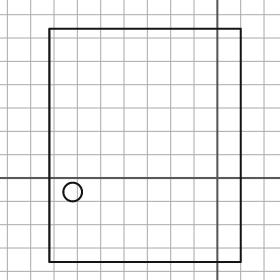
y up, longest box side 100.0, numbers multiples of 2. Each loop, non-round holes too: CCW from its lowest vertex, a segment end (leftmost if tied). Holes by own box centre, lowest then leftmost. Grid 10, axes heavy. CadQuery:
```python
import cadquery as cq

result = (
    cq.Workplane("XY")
    .moveTo(-72.0, -36.0)
    .lineTo(10.0, -36.0)
    .lineTo(10.0, 64.0)
    .lineTo(-72.0, 64.0)
    .close()
    .moveTo(-62.0, -6.0)
    .circle(4.0)
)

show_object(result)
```